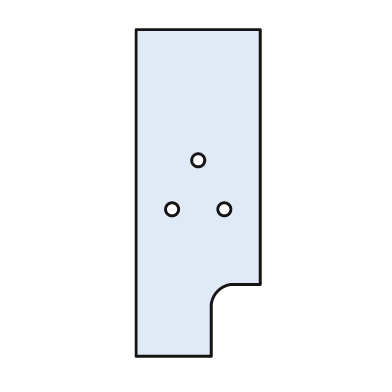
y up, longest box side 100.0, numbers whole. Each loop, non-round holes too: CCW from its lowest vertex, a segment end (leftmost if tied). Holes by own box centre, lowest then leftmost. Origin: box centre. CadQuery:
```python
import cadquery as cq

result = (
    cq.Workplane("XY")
    .moveTo(-19.0, -50.0)
    .lineTo(4.0, -50.0)
    .lineTo(4.0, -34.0)
    .threePointArc((6.0, -30.0), (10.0, -28.0))
    .lineTo(19.0, -28.0)
    .lineTo(19.0, 50.0)
    .lineTo(-19.0, 50.0)
    .close()
    .moveTo(-8.0, -5.0)
    .circle(2.0)
    .moveTo(8.0, -5.0)
    .circle(2.0)
    .moveTo(0.0, 10.0)
    .circle(2.0)
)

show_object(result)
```